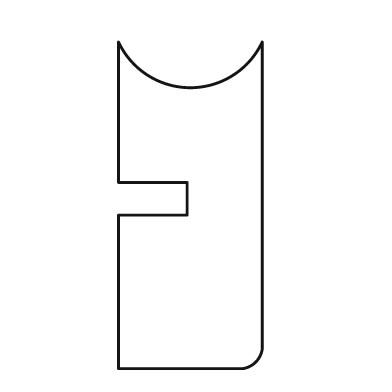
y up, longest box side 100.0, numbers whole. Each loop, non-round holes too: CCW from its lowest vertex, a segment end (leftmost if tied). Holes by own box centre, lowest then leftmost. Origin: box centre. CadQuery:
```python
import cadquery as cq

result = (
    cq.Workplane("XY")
    .moveTo(-22.0, -50.0)
    .lineTo(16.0, -50.0)
    .threePointArc((20.0, -48.0), (22.0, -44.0))
    .lineTo(22.0, 50.0)
    .threePointArc((0.0, 36.0), (-22.0, 50.0))
    .lineTo(-22.0, 7.0)
    .lineTo(-1.0, 7.0)
    .lineTo(-1.0, -3.0)
    .lineTo(-22.0, -3.0)
    .close()
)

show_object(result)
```